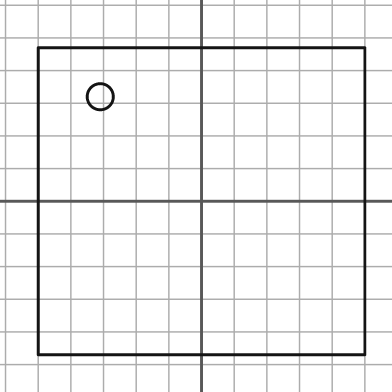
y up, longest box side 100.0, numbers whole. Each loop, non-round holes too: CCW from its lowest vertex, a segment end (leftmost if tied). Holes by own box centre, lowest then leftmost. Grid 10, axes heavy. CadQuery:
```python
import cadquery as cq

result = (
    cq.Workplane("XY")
    .moveTo(-50.0, -47.0)
    .lineTo(50.0, -47.0)
    .lineTo(50.0, 47.0)
    .lineTo(-50.0, 47.0)
    .close()
    .moveTo(-31.0, 32.0)
    .circle(4.0)
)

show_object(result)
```